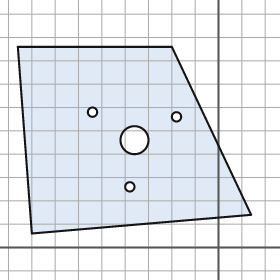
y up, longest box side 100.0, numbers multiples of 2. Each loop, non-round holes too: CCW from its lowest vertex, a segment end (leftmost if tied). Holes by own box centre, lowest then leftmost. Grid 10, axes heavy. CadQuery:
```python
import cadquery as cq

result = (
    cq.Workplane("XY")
    .moveTo(-80.0, 6.0)
    .lineTo(14.0, 14.0)
    .lineTo(-20.0, 86.0)
    .lineTo(-86.0, 86.0)
    .close()
    .moveTo(-38.0, 26.0)
    .circle(2.0)
    .moveTo(-36.0, 46.0)
    .circle(6.0)
    .moveTo(-18.0, 56.0)
    .circle(2.0)
    .moveTo(-54.0, 58.0)
    .circle(2.0)
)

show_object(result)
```